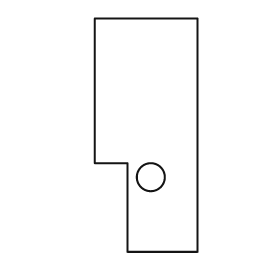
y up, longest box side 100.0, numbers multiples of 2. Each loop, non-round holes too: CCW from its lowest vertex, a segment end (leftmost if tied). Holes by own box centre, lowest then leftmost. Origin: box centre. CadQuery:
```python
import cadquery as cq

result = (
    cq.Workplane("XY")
    .moveTo(-8.0, -50.0)
    .lineTo(22.0, -50.0)
    .lineTo(22.0, 50.0)
    .lineTo(-22.0, 50.0)
    .lineTo(-22.0, -12.0)
    .lineTo(-8.0, -12.0)
    .close()
    .moveTo(2.0, -18.0)
    .circle(6.0)
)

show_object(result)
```